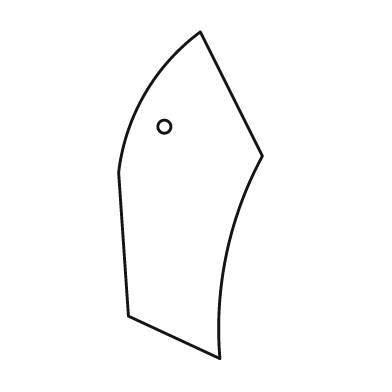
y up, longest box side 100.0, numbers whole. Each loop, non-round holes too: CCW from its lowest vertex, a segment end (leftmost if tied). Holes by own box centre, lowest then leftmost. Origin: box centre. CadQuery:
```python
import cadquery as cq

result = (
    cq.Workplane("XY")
    .moveTo(9.0, -50.0)
    .threePointArc((11.0, -18.0), (22.0, 12.0))
    .lineTo(3.0, 50.0)
    .threePointArc((-14.0, 31.0), (-22.0, 7.0))
    .lineTo(-19.0, -37.0)
    .close()
    .moveTo(-8.0, 21.0)
    .circle(2.0)
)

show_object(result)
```